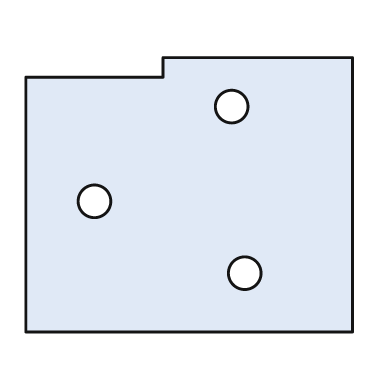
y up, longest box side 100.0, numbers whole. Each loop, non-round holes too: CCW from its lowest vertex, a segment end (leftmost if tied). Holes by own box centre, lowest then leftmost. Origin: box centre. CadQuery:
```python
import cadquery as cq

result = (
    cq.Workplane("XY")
    .moveTo(-50.0, -42.0)
    .lineTo(50.0, -42.0)
    .lineTo(50.0, 42.0)
    .lineTo(-8.0, 42.0)
    .lineTo(-8.0, 36.0)
    .lineTo(-50.0, 36.0)
    .close()
    .moveTo(17.0, -24.0)
    .circle(5.0)
    .moveTo(-29.0, -2.0)
    .circle(5.0)
    .moveTo(13.0, 27.0)
    .circle(5.0)
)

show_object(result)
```